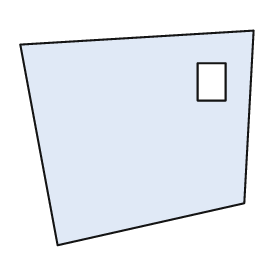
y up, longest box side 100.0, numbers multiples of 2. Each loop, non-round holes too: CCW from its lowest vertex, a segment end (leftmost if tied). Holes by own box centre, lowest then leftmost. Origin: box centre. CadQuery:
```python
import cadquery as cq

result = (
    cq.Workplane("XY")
    .moveTo(-34.0, -46.0)
    .lineTo(46.0, -28.0)
    .lineTo(50.0, 46.0)
    .lineTo(-50.0, 40.0)
    .close()
    .moveTo(26.0, 16.0)
    .lineTo(38.0, 16.0)
    .lineTo(38.0, 32.0)
    .lineTo(26.0, 32.0)
    .close()
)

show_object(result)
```